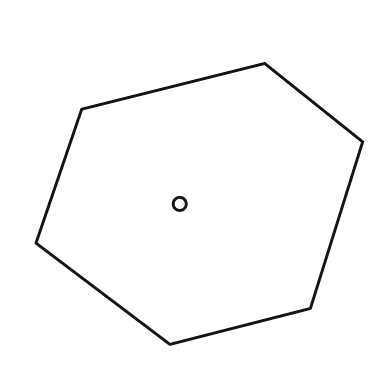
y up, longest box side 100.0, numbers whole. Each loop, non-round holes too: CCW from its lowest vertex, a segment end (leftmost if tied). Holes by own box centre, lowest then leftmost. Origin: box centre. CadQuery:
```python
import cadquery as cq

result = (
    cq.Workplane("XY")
    .moveTo(-9.0, -43.0)
    .lineTo(34.0, -32.0)
    .lineTo(50.0, 19.0)
    .lineTo(20.0, 43.0)
    .lineTo(-36.0, 29.0)
    .lineTo(-50.0, -12.0)
    .close()
    .moveTo(-6.0, 0.0)
    .circle(2.0)
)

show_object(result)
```